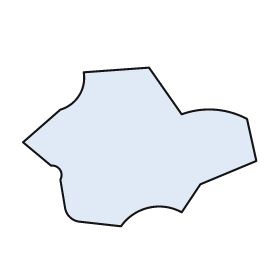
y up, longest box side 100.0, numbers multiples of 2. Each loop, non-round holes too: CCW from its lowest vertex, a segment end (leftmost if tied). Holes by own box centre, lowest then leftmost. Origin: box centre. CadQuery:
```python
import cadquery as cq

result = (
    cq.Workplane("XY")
    .moveTo(-8.0, -34.0)
    .threePointArc((4.0, -26.0), (18.0, -28.0))
    .lineTo(26.0, -16.0)
    .lineTo(50.0, -6.0)
    .lineTo(46.0, 12.0)
    .threePointArc((32.0, 16.0), (18.0, 14.0))
    .lineTo(4.0, 34.0)
    .lineTo(-24.0, 32.0)
    .threePointArc((-26.0, 22.0), (-34.0, 16.0))
    .lineTo(-50.0, 2.0)
    .lineTo(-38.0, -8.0)
    .threePointArc((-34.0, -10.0), (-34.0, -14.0))
    .lineTo(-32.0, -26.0)
    .threePointArc((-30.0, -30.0), (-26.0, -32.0))
    .close()
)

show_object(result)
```